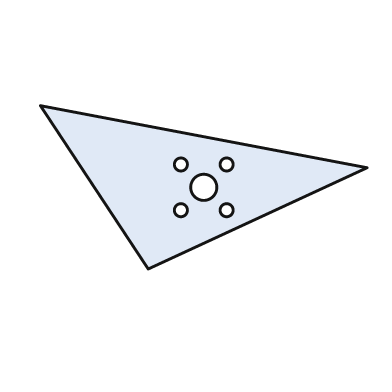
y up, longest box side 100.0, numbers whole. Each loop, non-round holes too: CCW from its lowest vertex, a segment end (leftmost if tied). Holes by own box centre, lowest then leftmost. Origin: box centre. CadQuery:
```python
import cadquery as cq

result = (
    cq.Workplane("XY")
    .moveTo(-17.0, -25.0)
    .lineTo(50.0, 6.0)
    .lineTo(-50.0, 25.0)
    .close()
    .moveTo(-7.0, -7.0)
    .circle(2.0)
    .moveTo(7.0, -7.0)
    .circle(2.0)
    .moveTo(0.0, 0.0)
    .circle(4.0)
    .moveTo(-7.0, 7.0)
    .circle(2.0)
    .moveTo(7.0, 7.0)
    .circle(2.0)
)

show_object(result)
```